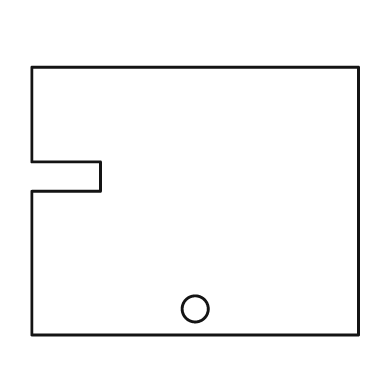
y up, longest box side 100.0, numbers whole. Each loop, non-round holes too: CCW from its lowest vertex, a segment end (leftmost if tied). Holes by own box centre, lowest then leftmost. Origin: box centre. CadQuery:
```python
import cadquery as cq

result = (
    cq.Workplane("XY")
    .moveTo(-50.0, -41.0)
    .lineTo(50.0, -41.0)
    .lineTo(50.0, 41.0)
    .lineTo(-50.0, 41.0)
    .lineTo(-50.0, 12.0)
    .lineTo(-29.0, 12.0)
    .lineTo(-29.0, 3.0)
    .lineTo(-50.0, 3.0)
    .close()
    .moveTo(0.0, -33.0)
    .circle(4.0)
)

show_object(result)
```